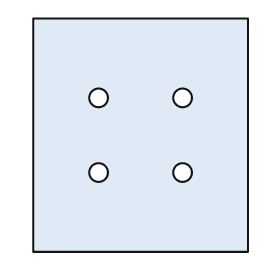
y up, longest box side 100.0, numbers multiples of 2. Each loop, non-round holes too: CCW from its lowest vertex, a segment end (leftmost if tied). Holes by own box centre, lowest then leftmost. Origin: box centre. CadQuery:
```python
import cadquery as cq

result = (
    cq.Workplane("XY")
    .moveTo(-46.0, -50.0)
    .lineTo(46.0, -50.0)
    .lineTo(46.0, 50.0)
    .lineTo(-46.0, 50.0)
    .close()
    .moveTo(-18.0, -16.0)
    .circle(4.0)
    .moveTo(18.0, -16.0)
    .circle(4.0)
    .moveTo(-18.0, 16.0)
    .circle(4.0)
    .moveTo(18.0, 16.0)
    .circle(4.0)
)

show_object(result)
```